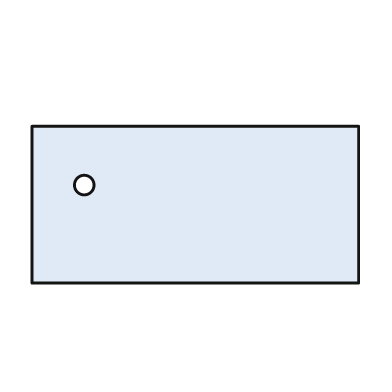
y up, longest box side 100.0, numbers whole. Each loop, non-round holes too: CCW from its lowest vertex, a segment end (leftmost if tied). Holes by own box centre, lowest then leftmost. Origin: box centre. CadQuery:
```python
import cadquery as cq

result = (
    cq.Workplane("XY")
    .moveTo(-50.0, -24.0)
    .lineTo(50.0, -24.0)
    .lineTo(50.0, 24.0)
    .lineTo(-50.0, 24.0)
    .close()
    .moveTo(-34.0, 6.0)
    .circle(3.0)
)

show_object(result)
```